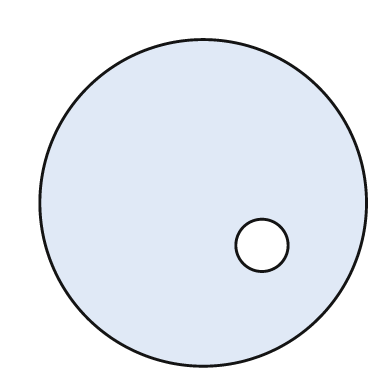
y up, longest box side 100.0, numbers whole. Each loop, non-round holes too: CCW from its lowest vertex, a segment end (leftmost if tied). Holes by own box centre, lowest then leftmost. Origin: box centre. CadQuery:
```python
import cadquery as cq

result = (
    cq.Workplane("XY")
    .moveTo(0.0, 0.0)
    .circle(50.0)
    .moveTo(18.0, -13.0)
    .circle(8.0)
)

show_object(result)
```